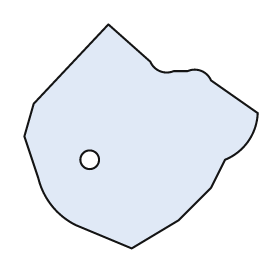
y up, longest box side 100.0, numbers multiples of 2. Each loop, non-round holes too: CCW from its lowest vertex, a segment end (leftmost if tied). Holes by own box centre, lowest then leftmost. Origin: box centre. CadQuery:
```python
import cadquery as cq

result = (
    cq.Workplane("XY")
    .moveTo(-4.0, -48.0)
    .lineTo(16.0, -36.0)
    .lineTo(30.0, -22.0)
    .lineTo(36.0, -10.0)
    .threePointArc((46.0, -2.0), (50.0, 10.0))
    .lineTo(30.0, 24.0)
    .threePointArc((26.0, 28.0), (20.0, 28.0))
    .lineTo(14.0, 28.0)
    .threePointArc((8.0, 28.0), (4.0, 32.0))
    .lineTo(-14.0, 48.0)
    .lineTo(-46.0, 14.0)
    .lineTo(-50.0, 0.0)
    .lineTo(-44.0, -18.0)
    .threePointArc((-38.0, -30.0), (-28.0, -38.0))
    .close()
    .moveTo(-22.0, -10.0)
    .circle(4.0)
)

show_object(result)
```